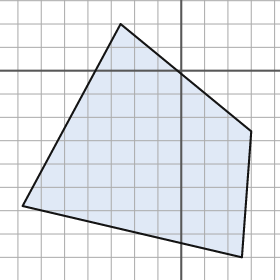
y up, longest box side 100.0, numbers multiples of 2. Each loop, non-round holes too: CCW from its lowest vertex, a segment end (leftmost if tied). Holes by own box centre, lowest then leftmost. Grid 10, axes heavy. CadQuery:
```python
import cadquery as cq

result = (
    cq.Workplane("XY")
    .moveTo(26.0, -80.0)
    .lineTo(30.0, -26.0)
    .lineTo(-26.0, 20.0)
    .lineTo(-68.0, -58.0)
    .close()
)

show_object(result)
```